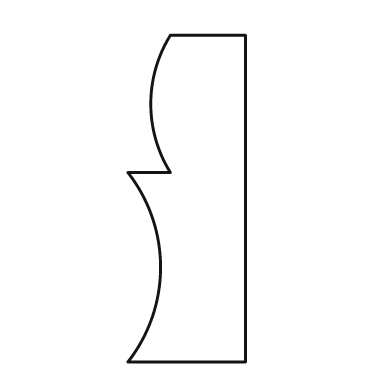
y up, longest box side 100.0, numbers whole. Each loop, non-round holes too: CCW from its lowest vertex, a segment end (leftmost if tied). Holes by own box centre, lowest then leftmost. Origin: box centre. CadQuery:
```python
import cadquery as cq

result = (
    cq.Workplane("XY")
    .moveTo(-18.0, -50.0)
    .lineTo(18.0, -50.0)
    .lineTo(18.0, 50.0)
    .lineTo(-5.0, 50.0)
    .threePointArc((-11.0, 29.0), (-5.0, 8.0))
    .lineTo(-18.0, 8.0)
    .threePointArc((-8.0, -21.0), (-18.0, -50.0))
    .close()
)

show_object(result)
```